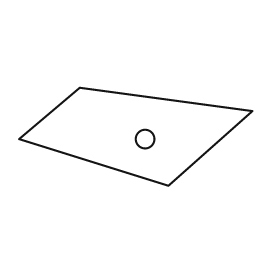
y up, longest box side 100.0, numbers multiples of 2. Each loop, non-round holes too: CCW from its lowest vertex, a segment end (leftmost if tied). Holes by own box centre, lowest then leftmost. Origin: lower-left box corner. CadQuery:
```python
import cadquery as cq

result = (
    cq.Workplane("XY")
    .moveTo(64.0, 0.0)
    .lineTo(100.0, 32.0)
    .lineTo(26.0, 42.0)
    .lineTo(0.0, 20.0)
    .close()
    .moveTo(54.0, 20.0)
    .circle(4.0)
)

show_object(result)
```